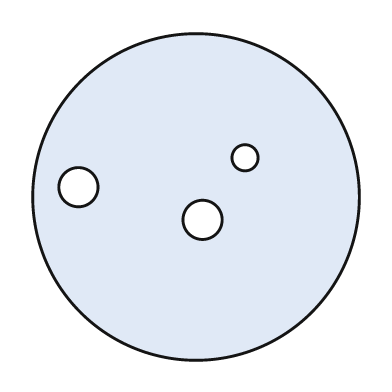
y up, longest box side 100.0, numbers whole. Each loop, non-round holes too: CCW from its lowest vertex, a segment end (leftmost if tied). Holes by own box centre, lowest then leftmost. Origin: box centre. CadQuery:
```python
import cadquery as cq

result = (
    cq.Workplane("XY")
    .moveTo(0.0, 0.0)
    .circle(50.0)
    .moveTo(2.0, -7.0)
    .circle(6.0)
    .moveTo(-36.0, 3.0)
    .circle(6.0)
    .moveTo(15.0, 12.0)
    .circle(4.0)
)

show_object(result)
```